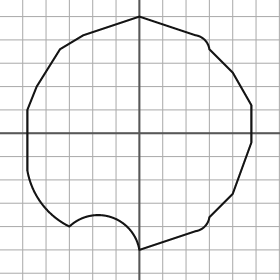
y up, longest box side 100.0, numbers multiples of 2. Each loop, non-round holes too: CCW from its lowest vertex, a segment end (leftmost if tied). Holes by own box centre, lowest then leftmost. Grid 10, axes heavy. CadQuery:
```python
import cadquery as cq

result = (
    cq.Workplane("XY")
    .moveTo(0.0, -50.0)
    .lineTo(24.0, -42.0)
    .threePointArc((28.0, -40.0), (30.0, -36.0))
    .lineTo(40.0, -26.0)
    .lineTo(48.0, -4.0)
    .lineTo(48.0, 12.0)
    .lineTo(40.0, 26.0)
    .lineTo(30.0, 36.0)
    .threePointArc((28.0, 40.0), (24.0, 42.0))
    .lineTo(0.0, 50.0)
    .lineTo(-24.0, 42.0)
    .lineTo(-34.0, 36.0)
    .lineTo(-44.0, 20.0)
    .lineTo(-48.0, 10.0)
    .lineTo(-48.0, -16.0)
    .threePointArc((-42.0, -30.0), (-30.0, -40.0))
    .threePointArc((-12.0, -36.0), (0.0, -50.0))
    .close()
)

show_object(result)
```